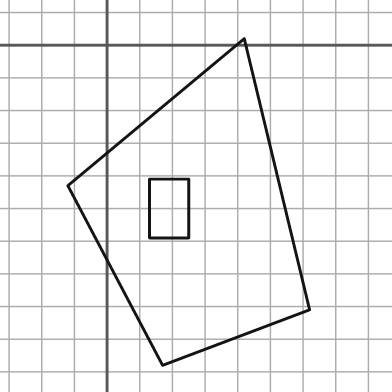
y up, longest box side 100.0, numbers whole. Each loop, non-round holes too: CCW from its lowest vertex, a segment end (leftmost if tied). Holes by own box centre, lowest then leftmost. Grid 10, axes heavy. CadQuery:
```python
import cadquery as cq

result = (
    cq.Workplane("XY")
    .moveTo(17.0, -98.0)
    .lineTo(62.0, -81.0)
    .lineTo(42.0, 2.0)
    .lineTo(-12.0, -43.0)
    .close()
    .moveTo(13.0, -59.0)
    .lineTo(25.0, -59.0)
    .lineTo(25.0, -41.0)
    .lineTo(13.0, -41.0)
    .close()
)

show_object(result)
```